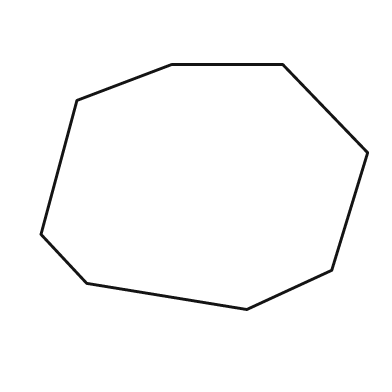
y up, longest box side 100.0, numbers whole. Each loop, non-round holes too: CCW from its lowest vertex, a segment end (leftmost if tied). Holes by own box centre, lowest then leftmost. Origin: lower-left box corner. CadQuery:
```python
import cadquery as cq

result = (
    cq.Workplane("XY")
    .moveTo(63.0, 0.0)
    .lineTo(89.0, 12.0)
    .lineTo(100.0, 48.0)
    .lineTo(74.0, 75.0)
    .lineTo(40.0, 75.0)
    .lineTo(11.0, 64.0)
    .lineTo(0.0, 23.0)
    .lineTo(14.0, 8.0)
    .close()
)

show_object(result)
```